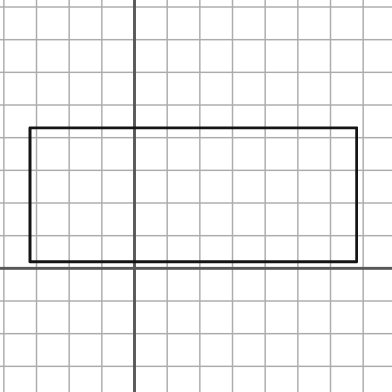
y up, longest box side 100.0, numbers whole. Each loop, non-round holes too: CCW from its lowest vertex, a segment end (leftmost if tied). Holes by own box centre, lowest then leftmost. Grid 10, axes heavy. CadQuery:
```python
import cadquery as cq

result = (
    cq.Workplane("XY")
    .moveTo(-32.0, 2.0)
    .lineTo(68.0, 2.0)
    .lineTo(68.0, 43.0)
    .lineTo(-32.0, 43.0)
    .close()
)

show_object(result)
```